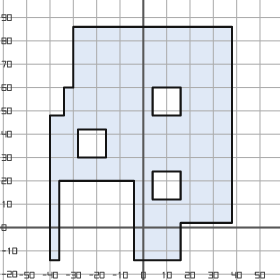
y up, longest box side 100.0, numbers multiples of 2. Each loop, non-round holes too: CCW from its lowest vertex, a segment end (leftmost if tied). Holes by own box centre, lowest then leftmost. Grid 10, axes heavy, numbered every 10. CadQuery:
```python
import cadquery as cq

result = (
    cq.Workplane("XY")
    .moveTo(-40.0, -14.0)
    .lineTo(-36.0, -14.0)
    .lineTo(-36.0, 20.0)
    .lineTo(-4.0, 20.0)
    .lineTo(-4.0, -14.0)
    .lineTo(16.0, -14.0)
    .lineTo(16.0, 2.0)
    .lineTo(38.0, 2.0)
    .lineTo(38.0, 86.0)
    .lineTo(-30.0, 86.0)
    .lineTo(-30.0, 60.0)
    .lineTo(-34.0, 60.0)
    .lineTo(-34.0, 48.0)
    .lineTo(-40.0, 48.0)
    .close()
    .moveTo(4.0, 12.0)
    .lineTo(16.0, 12.0)
    .lineTo(16.0, 24.0)
    .lineTo(4.0, 24.0)
    .close()
    .moveTo(-28.0, 30.0)
    .lineTo(-16.0, 30.0)
    .lineTo(-16.0, 42.0)
    .lineTo(-28.0, 42.0)
    .close()
    .moveTo(4.0, 48.0)
    .lineTo(16.0, 48.0)
    .lineTo(16.0, 60.0)
    .lineTo(4.0, 60.0)
    .close()
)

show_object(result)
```